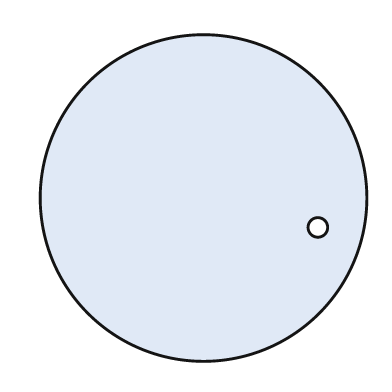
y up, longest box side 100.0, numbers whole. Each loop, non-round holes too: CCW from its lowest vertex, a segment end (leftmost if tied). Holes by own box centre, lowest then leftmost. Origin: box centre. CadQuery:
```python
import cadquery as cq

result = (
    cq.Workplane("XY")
    .moveTo(0.0, 0.0)
    .circle(50.0)
    .moveTo(35.0, -9.0)
    .circle(3.0)
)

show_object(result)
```